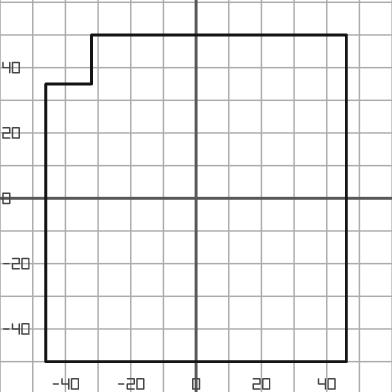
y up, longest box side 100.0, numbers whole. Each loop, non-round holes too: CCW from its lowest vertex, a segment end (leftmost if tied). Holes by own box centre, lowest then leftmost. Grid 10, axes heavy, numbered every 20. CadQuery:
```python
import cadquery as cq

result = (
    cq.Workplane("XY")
    .moveTo(-46.0, -50.0)
    .lineTo(46.0, -50.0)
    .lineTo(46.0, 50.0)
    .lineTo(-32.0, 50.0)
    .lineTo(-32.0, 35.0)
    .lineTo(-46.0, 35.0)
    .close()
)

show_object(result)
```